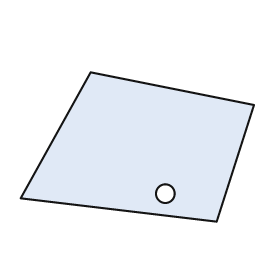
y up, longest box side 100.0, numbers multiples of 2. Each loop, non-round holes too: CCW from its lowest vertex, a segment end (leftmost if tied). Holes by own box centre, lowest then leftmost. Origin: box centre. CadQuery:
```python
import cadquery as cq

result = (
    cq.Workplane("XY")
    .moveTo(34.0, -32.0)
    .lineTo(50.0, 18.0)
    .lineTo(-20.0, 32.0)
    .lineTo(-50.0, -22.0)
    .close()
    .moveTo(12.0, -20.0)
    .circle(4.0)
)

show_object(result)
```